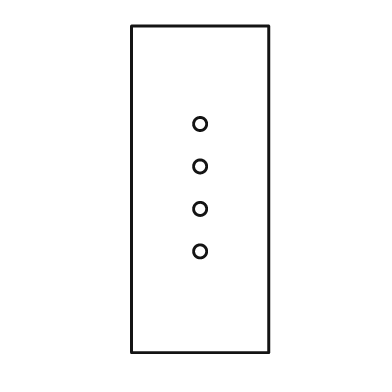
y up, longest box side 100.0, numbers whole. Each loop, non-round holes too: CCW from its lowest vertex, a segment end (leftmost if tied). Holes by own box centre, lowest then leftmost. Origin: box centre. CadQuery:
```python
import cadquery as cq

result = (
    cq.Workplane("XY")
    .moveTo(-21.0, -50.0)
    .lineTo(21.0, -50.0)
    .lineTo(21.0, 50.0)
    .lineTo(-21.0, 50.0)
    .close()
    .moveTo(0.0, -19.0)
    .circle(2.0)
    .moveTo(0.0, -6.0)
    .circle(2.0)
    .moveTo(0.0, 7.0)
    .circle(2.0)
    .moveTo(0.0, 20.0)
    .circle(2.0)
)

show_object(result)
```